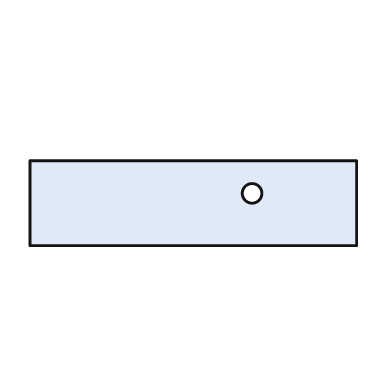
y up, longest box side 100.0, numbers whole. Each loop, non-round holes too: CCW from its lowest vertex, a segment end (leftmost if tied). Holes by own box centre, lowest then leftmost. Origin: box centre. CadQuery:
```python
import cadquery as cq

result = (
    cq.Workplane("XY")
    .moveTo(-50.0, -13.0)
    .lineTo(50.0, -13.0)
    .lineTo(50.0, 13.0)
    .lineTo(-50.0, 13.0)
    .close()
    .moveTo(18.0, 3.0)
    .circle(3.0)
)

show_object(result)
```